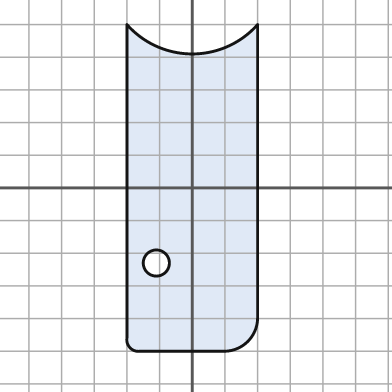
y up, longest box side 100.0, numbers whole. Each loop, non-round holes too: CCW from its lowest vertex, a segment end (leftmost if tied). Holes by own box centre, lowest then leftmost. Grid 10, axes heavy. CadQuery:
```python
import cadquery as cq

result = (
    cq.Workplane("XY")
    .moveTo(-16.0, -50.0)
    .lineTo(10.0, -50.0)
    .threePointArc((17.0, -47.0), (20.0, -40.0))
    .lineTo(20.0, 50.0)
    .threePointArc((0.0, 41.0), (-20.0, 50.0))
    .lineTo(-20.0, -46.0)
    .threePointArc((-19.0, -49.0), (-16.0, -50.0))
    .close()
    .moveTo(-11.0, -23.0)
    .circle(4.0)
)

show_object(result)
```